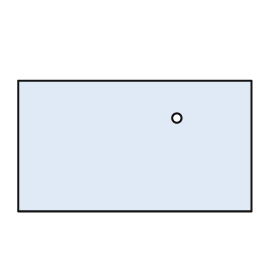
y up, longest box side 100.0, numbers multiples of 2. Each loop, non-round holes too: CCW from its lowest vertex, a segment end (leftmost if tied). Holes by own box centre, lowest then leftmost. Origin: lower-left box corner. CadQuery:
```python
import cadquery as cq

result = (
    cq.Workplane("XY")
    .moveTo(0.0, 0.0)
    .lineTo(100.0, 0.0)
    .lineTo(100.0, 56.0)
    .lineTo(0.0, 56.0)
    .close()
    .moveTo(68.0, 40.0)
    .circle(2.0)
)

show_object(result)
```